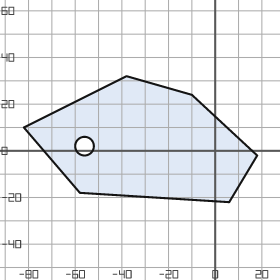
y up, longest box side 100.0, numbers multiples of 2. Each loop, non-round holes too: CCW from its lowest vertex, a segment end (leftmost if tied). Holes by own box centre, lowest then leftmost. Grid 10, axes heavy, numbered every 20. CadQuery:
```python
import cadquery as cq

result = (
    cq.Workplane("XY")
    .moveTo(6.0, -22.0)
    .lineTo(18.0, -2.0)
    .lineTo(-10.0, 24.0)
    .lineTo(-38.0, 32.0)
    .lineTo(-82.0, 10.0)
    .lineTo(-58.0, -18.0)
    .close()
    .moveTo(-56.0, 2.0)
    .circle(4.0)
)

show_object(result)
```